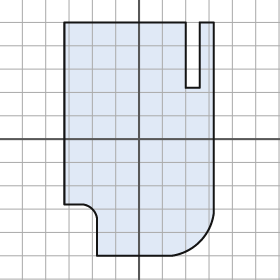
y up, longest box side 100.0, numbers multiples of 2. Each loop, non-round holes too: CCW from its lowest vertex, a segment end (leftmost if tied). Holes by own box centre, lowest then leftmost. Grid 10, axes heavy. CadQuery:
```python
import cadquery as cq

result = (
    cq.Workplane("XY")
    .moveTo(-18.0, -50.0)
    .lineTo(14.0, -50.0)
    .threePointArc((26.0, -44.0), (32.0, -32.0))
    .lineTo(32.0, 50.0)
    .lineTo(26.0, 50.0)
    .lineTo(26.0, 22.0)
    .lineTo(20.0, 22.0)
    .lineTo(20.0, 50.0)
    .lineTo(-32.0, 50.0)
    .lineTo(-32.0, -28.0)
    .lineTo(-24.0, -28.0)
    .threePointArc((-20.0, -30.0), (-18.0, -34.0))
    .close()
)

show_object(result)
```